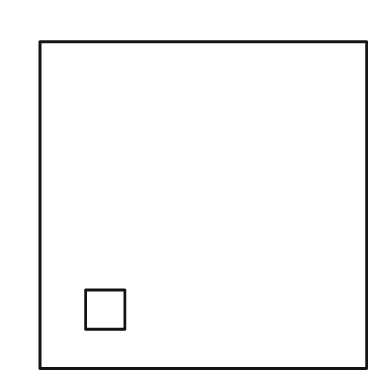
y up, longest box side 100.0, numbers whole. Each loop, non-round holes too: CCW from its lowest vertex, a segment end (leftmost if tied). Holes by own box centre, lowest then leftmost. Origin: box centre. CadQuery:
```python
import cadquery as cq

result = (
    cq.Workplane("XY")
    .moveTo(-50.0, -50.0)
    .lineTo(50.0, -50.0)
    .lineTo(50.0, 50.0)
    .lineTo(-50.0, 50.0)
    .close()
    .moveTo(-36.0, -38.0)
    .lineTo(-24.0, -38.0)
    .lineTo(-24.0, -26.0)
    .lineTo(-36.0, -26.0)
    .close()
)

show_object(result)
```